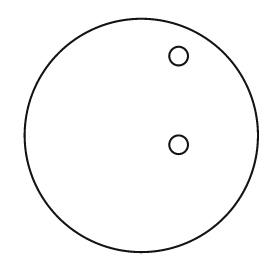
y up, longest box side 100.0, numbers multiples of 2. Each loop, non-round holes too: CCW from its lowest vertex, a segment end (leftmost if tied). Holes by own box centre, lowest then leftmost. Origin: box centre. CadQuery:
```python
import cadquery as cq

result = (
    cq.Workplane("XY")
    .moveTo(0.0, 0.0)
    .circle(50.0)
    .moveTo(16.0, -4.0)
    .circle(4.0)
    .moveTo(16.0, 34.0)
    .circle(4.0)
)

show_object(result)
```